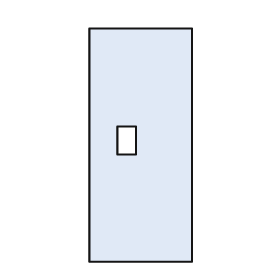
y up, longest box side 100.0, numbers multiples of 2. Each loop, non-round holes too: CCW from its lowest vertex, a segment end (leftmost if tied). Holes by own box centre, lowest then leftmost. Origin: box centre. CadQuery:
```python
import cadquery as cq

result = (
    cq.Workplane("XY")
    .moveTo(-22.0, -50.0)
    .lineTo(22.0, -50.0)
    .lineTo(22.0, 50.0)
    .lineTo(-22.0, 50.0)
    .close()
    .moveTo(-10.0, -4.0)
    .lineTo(-2.0, -4.0)
    .lineTo(-2.0, 8.0)
    .lineTo(-10.0, 8.0)
    .close()
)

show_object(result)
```